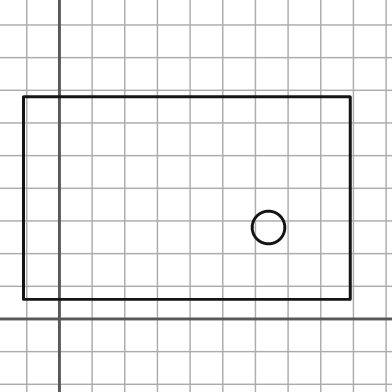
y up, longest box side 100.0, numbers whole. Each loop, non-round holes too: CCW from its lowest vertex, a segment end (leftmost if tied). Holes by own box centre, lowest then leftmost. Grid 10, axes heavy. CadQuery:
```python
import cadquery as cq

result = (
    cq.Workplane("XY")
    .moveTo(-11.0, 6.0)
    .lineTo(89.0, 6.0)
    .lineTo(89.0, 68.0)
    .lineTo(-11.0, 68.0)
    .close()
    .moveTo(64.0, 28.0)
    .circle(5.0)
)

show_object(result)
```